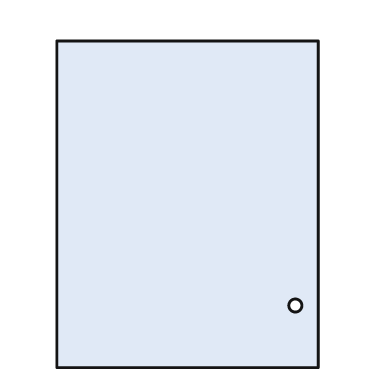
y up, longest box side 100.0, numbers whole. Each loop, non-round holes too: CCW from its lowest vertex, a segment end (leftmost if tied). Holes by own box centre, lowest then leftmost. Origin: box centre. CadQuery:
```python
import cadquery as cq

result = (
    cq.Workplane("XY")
    .moveTo(-40.0, -50.0)
    .lineTo(40.0, -50.0)
    .lineTo(40.0, 50.0)
    .lineTo(-40.0, 50.0)
    .close()
    .moveTo(33.0, -31.0)
    .circle(2.0)
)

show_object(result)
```